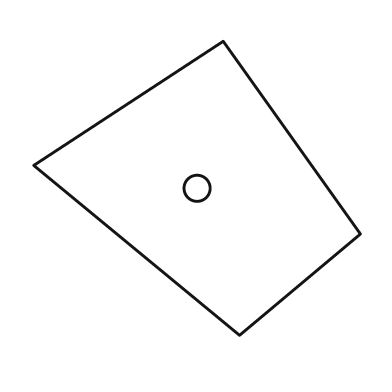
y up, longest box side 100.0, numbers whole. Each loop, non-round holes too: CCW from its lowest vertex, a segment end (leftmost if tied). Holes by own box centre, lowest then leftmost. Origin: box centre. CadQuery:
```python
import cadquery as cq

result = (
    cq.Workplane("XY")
    .moveTo(13.0, -45.0)
    .lineTo(50.0, -14.0)
    .lineTo(8.0, 45.0)
    .lineTo(-50.0, 7.0)
    .close()
    .moveTo(0.0, 0.0)
    .circle(4.0)
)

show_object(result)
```